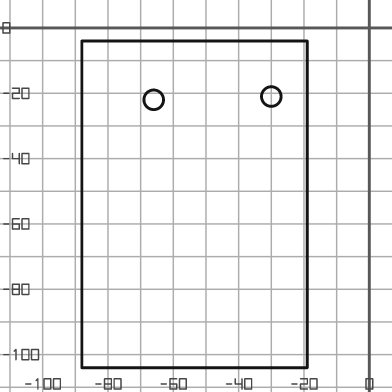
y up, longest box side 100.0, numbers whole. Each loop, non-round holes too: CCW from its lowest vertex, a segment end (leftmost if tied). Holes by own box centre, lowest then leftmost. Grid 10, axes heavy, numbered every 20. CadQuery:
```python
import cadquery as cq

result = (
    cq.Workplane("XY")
    .moveTo(-88.0, -104.0)
    .lineTo(-19.0, -104.0)
    .lineTo(-19.0, -4.0)
    .lineTo(-88.0, -4.0)
    .close()
    .moveTo(-66.0, -22.0)
    .circle(3.0)
    .moveTo(-30.0, -21.0)
    .circle(3.0)
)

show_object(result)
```